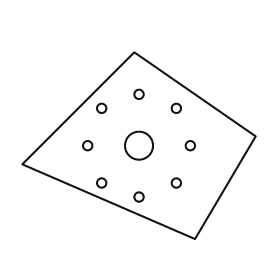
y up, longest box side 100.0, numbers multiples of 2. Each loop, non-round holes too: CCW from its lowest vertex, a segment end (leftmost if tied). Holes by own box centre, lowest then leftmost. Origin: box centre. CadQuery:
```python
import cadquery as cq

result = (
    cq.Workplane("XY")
    .moveTo(24.0, -40.0)
    .lineTo(50.0, 4.0)
    .lineTo(-2.0, 40.0)
    .lineTo(-50.0, -8.0)
    .close()
    .moveTo(0.0, -22.0)
    .circle(2.0)
    .moveTo(-16.0, -16.0)
    .circle(2.0)
    .moveTo(16.0, -16.0)
    .circle(2.0)
    .moveTo(-22.0, 0.0)
    .circle(2.0)
    .moveTo(0.0, 0.0)
    .circle(6.0)
    .moveTo(22.0, 0.0)
    .circle(2.0)
    .moveTo(-16.0, 16.0)
    .circle(2.0)
    .moveTo(16.0, 16.0)
    .circle(2.0)
    .moveTo(0.0, 22.0)
    .circle(2.0)
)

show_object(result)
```